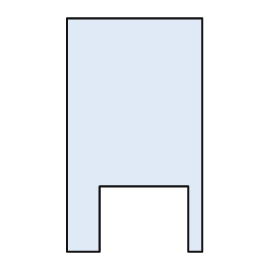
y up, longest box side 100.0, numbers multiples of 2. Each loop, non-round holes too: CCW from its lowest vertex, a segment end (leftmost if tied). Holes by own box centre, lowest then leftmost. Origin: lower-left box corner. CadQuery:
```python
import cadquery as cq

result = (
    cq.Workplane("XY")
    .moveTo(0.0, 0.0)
    .lineTo(14.0, 0.0)
    .lineTo(14.0, 28.0)
    .lineTo(52.0, 28.0)
    .lineTo(52.0, 0.0)
    .lineTo(58.0, 0.0)
    .lineTo(58.0, 100.0)
    .lineTo(0.0, 100.0)
    .close()
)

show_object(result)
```